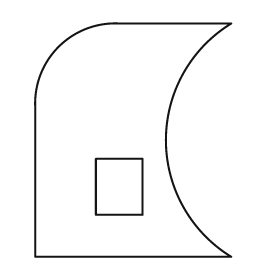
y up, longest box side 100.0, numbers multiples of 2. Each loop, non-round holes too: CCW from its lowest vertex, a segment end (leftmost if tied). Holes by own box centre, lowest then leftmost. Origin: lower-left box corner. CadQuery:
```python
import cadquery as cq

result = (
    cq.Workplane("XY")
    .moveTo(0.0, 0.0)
    .lineTo(84.0, 0.0)
    .threePointArc((56.0, 50.0), (84.0, 100.0))
    .lineTo(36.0, 100.0)
    .threePointArc((10.0, 90.0), (0.0, 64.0))
    .close()
    .moveTo(26.0, 18.0)
    .lineTo(46.0, 18.0)
    .lineTo(46.0, 42.0)
    .lineTo(26.0, 42.0)
    .close()
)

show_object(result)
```